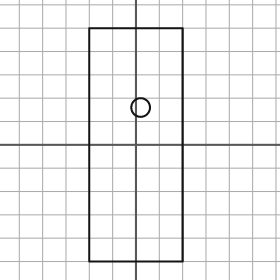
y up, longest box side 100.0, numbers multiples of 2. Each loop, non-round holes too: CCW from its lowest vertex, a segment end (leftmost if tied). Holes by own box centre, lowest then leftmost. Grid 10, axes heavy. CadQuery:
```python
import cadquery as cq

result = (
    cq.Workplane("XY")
    .moveTo(-20.0, -50.0)
    .lineTo(20.0, -50.0)
    .lineTo(20.0, 50.0)
    .lineTo(-20.0, 50.0)
    .close()
    .moveTo(2.0, 16.0)
    .circle(4.0)
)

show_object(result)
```